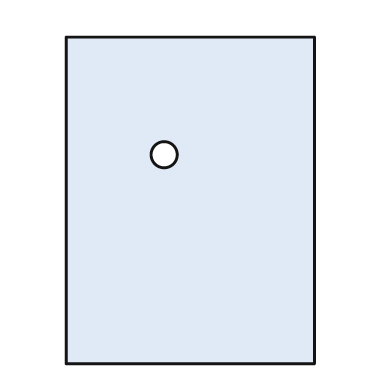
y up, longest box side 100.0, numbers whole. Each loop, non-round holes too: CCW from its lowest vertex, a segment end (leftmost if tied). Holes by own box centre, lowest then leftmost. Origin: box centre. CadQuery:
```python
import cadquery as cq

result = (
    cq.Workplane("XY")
    .moveTo(-38.0, -50.0)
    .lineTo(38.0, -50.0)
    .lineTo(38.0, 50.0)
    .lineTo(-38.0, 50.0)
    .close()
    .moveTo(-8.0, 14.0)
    .circle(4.0)
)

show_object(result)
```